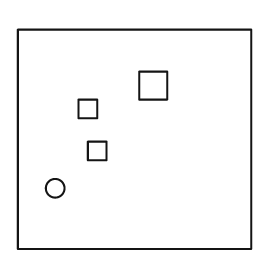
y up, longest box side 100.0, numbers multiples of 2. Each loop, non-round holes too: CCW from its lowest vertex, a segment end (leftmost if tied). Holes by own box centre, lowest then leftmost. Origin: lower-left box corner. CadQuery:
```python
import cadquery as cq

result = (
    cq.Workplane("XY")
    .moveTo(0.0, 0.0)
    .lineTo(100.0, 0.0)
    .lineTo(100.0, 94.0)
    .lineTo(0.0, 94.0)
    .close()
    .moveTo(16.0, 26.0)
    .circle(4.0)
    .moveTo(30.0, 38.0)
    .lineTo(38.0, 38.0)
    .lineTo(38.0, 46.0)
    .lineTo(30.0, 46.0)
    .close()
    .moveTo(26.0, 56.0)
    .lineTo(34.0, 56.0)
    .lineTo(34.0, 64.0)
    .lineTo(26.0, 64.0)
    .close()
    .moveTo(52.0, 64.0)
    .lineTo(64.0, 64.0)
    .lineTo(64.0, 76.0)
    .lineTo(52.0, 76.0)
    .close()
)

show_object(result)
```